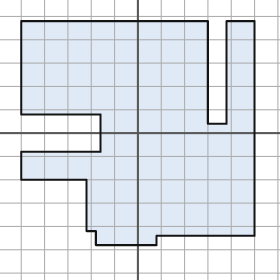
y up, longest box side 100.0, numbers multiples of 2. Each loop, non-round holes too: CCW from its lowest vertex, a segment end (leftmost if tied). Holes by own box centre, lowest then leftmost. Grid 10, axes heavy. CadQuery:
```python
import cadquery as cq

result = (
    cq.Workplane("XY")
    .moveTo(-18.0, -48.0)
    .lineTo(8.0, -48.0)
    .lineTo(8.0, -44.0)
    .lineTo(50.0, -44.0)
    .lineTo(50.0, 48.0)
    .lineTo(38.0, 48.0)
    .lineTo(38.0, 4.0)
    .lineTo(30.0, 4.0)
    .lineTo(30.0, 48.0)
    .lineTo(-50.0, 48.0)
    .lineTo(-50.0, 8.0)
    .lineTo(-16.0, 8.0)
    .lineTo(-16.0, -8.0)
    .lineTo(-50.0, -8.0)
    .lineTo(-50.0, -20.0)
    .lineTo(-22.0, -20.0)
    .lineTo(-22.0, -42.0)
    .lineTo(-18.0, -42.0)
    .close()
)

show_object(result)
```